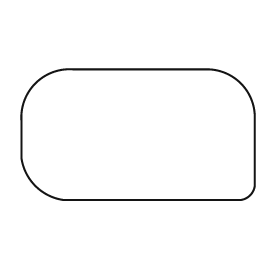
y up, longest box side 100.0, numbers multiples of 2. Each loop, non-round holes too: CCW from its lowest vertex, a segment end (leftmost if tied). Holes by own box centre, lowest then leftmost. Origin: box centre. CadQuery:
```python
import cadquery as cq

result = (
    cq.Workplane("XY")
    .moveTo(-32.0, -28.0)
    .lineTo(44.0, -28.0)
    .threePointArc((48.0, -26.0), (50.0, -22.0))
    .lineTo(50.0, 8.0)
    .threePointArc((44.0, 22.0), (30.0, 28.0))
    .lineTo(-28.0, 28.0)
    .threePointArc((-44.0, 22.0), (-50.0, 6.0))
    .lineTo(-50.0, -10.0)
    .threePointArc((-44.0, -22.0), (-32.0, -28.0))
    .close()
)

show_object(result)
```